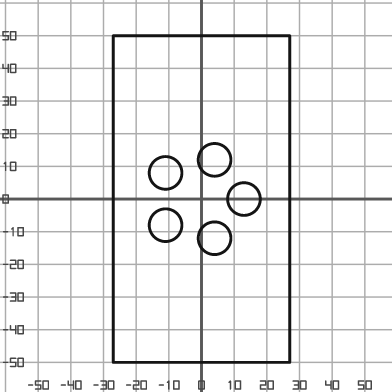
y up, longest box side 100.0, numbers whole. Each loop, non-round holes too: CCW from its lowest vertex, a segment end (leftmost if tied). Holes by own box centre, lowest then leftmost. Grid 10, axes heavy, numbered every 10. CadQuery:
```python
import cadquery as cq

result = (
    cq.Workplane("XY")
    .moveTo(-27.0, -50.0)
    .lineTo(27.0, -50.0)
    .lineTo(27.0, 50.0)
    .lineTo(-27.0, 50.0)
    .close()
    .moveTo(4.0, -12.0)
    .circle(5.0)
    .moveTo(-11.0, -8.0)
    .circle(5.0)
    .moveTo(13.0, 0.0)
    .circle(5.0)
    .moveTo(-11.0, 8.0)
    .circle(5.0)
    .moveTo(4.0, 12.0)
    .circle(5.0)
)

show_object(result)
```